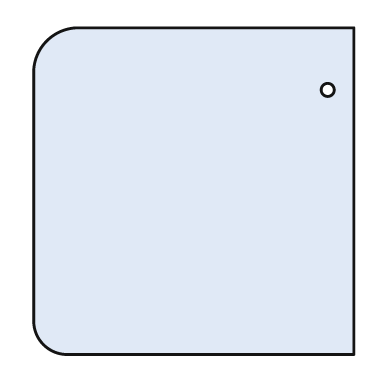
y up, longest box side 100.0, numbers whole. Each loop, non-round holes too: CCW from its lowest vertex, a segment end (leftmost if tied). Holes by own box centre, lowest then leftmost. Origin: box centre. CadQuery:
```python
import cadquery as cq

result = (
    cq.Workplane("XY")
    .moveTo(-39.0, -50.0)
    .lineTo(49.0, -50.0)
    .lineTo(49.0, 50.0)
    .lineTo(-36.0, 50.0)
    .threePointArc((-45.0, 46.0), (-49.0, 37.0))
    .lineTo(-49.0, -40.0)
    .threePointArc((-46.0, -47.0), (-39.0, -50.0))
    .close()
    .moveTo(41.0, 31.0)
    .circle(2.0)
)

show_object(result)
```